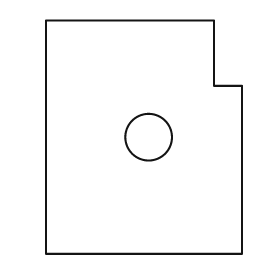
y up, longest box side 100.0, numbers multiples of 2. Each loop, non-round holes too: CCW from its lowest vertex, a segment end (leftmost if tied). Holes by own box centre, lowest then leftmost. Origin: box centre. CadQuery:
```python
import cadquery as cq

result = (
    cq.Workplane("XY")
    .moveTo(-42.0, -50.0)
    .lineTo(42.0, -50.0)
    .lineTo(42.0, 22.0)
    .lineTo(30.0, 22.0)
    .lineTo(30.0, 50.0)
    .lineTo(-42.0, 50.0)
    .close()
    .moveTo(2.0, 0.0)
    .circle(10.0)
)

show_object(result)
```